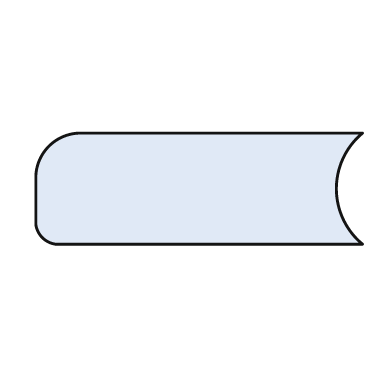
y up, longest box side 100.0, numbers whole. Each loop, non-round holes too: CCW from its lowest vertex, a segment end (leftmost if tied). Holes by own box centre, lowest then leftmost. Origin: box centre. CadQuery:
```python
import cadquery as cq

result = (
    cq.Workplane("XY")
    .moveTo(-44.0, -17.0)
    .lineTo(50.0, -17.0)
    .threePointArc((42.0, 0.0), (50.0, 17.0))
    .lineTo(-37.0, 17.0)
    .threePointArc((-46.0, 13.0), (-50.0, 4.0))
    .lineTo(-50.0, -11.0)
    .threePointArc((-48.0, -15.0), (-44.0, -17.0))
    .close()
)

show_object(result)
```